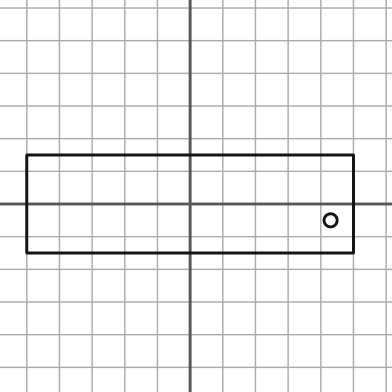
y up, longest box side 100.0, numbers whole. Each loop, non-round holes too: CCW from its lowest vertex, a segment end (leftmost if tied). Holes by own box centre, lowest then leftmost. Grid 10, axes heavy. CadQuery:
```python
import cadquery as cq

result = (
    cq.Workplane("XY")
    .moveTo(-50.0, -15.0)
    .lineTo(50.0, -15.0)
    .lineTo(50.0, 15.0)
    .lineTo(-50.0, 15.0)
    .close()
    .moveTo(43.0, -5.0)
    .circle(2.0)
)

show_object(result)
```